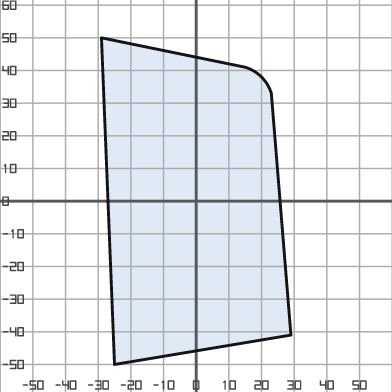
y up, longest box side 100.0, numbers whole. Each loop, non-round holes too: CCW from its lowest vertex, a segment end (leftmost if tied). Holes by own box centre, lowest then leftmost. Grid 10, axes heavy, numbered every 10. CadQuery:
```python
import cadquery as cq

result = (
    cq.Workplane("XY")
    .moveTo(-25.0, -50.0)
    .lineTo(29.0, -41.0)
    .lineTo(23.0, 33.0)
    .threePointArc((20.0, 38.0), (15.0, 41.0))
    .lineTo(-29.0, 50.0)
    .close()
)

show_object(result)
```